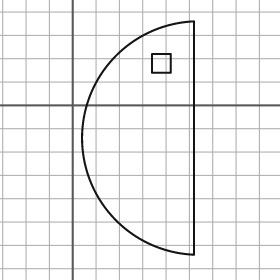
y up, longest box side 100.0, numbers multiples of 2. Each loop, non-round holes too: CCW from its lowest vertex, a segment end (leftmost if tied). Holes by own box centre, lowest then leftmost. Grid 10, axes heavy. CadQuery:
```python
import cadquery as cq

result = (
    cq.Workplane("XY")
    .moveTo(52.0, -64.0)
    .lineTo(52.0, 36.0)
    .threePointArc((4.0, -14.0), (52.0, -64.0))
    .close()
    .moveTo(34.0, 14.0)
    .lineTo(42.0, 14.0)
    .lineTo(42.0, 22.0)
    .lineTo(34.0, 22.0)
    .close()
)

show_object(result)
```